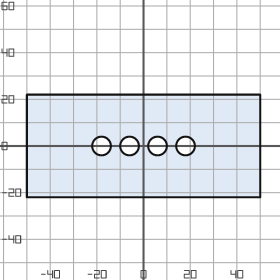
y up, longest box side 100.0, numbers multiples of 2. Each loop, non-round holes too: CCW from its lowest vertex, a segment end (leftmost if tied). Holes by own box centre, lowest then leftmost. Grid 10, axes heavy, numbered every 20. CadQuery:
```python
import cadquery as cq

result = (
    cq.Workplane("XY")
    .moveTo(-50.0, -22.0)
    .lineTo(50.0, -22.0)
    .lineTo(50.0, 22.0)
    .lineTo(-50.0, 22.0)
    .close()
    .moveTo(-18.0, 0.0)
    .circle(4.0)
    .moveTo(-6.0, 0.0)
    .circle(4.0)
    .moveTo(6.0, 0.0)
    .circle(4.0)
    .moveTo(18.0, 0.0)
    .circle(4.0)
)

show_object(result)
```